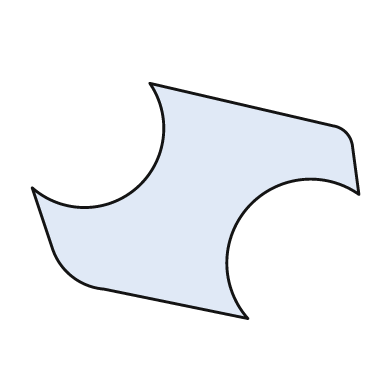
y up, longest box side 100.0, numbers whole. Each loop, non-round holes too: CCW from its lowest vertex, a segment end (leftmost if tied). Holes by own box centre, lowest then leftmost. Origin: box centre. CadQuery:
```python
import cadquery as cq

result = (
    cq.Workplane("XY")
    .moveTo(16.0, -36.0)
    .threePointArc((16.0, -2.0), (50.0, 2.0))
    .lineTo(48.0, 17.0)
    .threePointArc((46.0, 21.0), (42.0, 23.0))
    .lineTo(-14.0, 36.0)
    .threePointArc((-18.0, 4.0), (-50.0, 4.0))
    .lineTo(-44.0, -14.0)
    .threePointArc((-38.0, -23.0), (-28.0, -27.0))
    .close()
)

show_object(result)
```